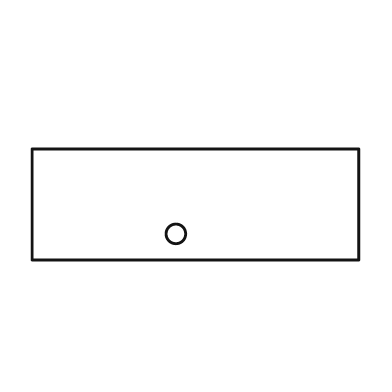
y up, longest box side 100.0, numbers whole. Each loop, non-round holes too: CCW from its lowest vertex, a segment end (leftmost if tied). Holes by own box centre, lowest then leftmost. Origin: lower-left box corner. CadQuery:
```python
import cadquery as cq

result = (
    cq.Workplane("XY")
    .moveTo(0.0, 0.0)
    .lineTo(100.0, 0.0)
    .lineTo(100.0, 34.0)
    .lineTo(0.0, 34.0)
    .close()
    .moveTo(44.0, 8.0)
    .circle(3.0)
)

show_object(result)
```